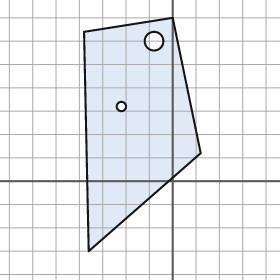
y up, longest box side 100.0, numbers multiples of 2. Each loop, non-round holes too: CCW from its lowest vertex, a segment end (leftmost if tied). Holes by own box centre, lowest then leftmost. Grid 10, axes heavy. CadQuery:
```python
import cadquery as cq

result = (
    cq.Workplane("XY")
    .moveTo(-36.0, -30.0)
    .lineTo(12.0, 12.0)
    .lineTo(0.0, 70.0)
    .lineTo(-38.0, 64.0)
    .close()
    .moveTo(-22.0, 32.0)
    .circle(2.0)
    .moveTo(-8.0, 60.0)
    .circle(4.0)
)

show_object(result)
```